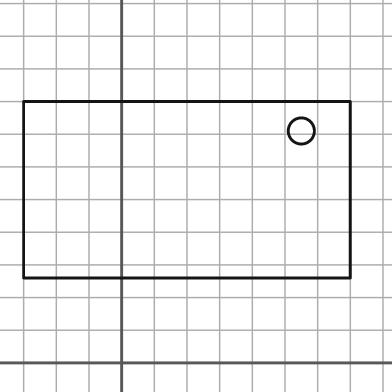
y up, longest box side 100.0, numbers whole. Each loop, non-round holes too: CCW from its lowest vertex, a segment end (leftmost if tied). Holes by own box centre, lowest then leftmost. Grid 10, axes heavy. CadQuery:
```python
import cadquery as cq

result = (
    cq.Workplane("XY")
    .moveTo(-30.0, 26.0)
    .lineTo(70.0, 26.0)
    .lineTo(70.0, 80.0)
    .lineTo(-30.0, 80.0)
    .close()
    .moveTo(55.0, 71.0)
    .circle(4.0)
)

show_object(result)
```